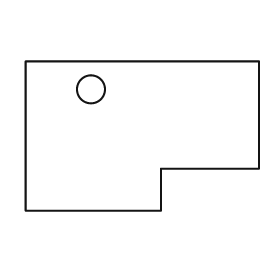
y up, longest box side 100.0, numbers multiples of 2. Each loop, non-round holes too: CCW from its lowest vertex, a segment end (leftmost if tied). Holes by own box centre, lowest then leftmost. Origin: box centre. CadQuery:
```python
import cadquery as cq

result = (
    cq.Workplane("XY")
    .moveTo(-50.0, -32.0)
    .lineTo(8.0, -32.0)
    .lineTo(8.0, -14.0)
    .lineTo(50.0, -14.0)
    .lineTo(50.0, 32.0)
    .lineTo(-50.0, 32.0)
    .close()
    .moveTo(-22.0, 20.0)
    .circle(6.0)
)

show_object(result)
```